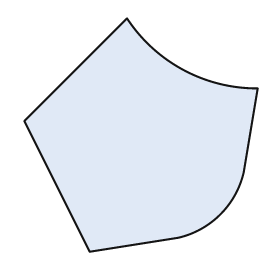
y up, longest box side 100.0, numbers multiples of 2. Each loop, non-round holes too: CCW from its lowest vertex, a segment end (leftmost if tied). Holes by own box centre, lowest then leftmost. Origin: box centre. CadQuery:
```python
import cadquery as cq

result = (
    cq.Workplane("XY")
    .moveTo(-22.0, -50.0)
    .lineTo(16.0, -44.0)
    .threePointArc((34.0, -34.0), (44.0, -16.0))
    .lineTo(50.0, 20.0)
    .threePointArc((18.0, 28.0), (-6.0, 50.0))
    .lineTo(-50.0, 6.0)
    .close()
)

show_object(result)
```